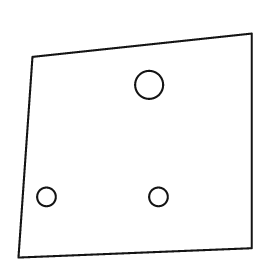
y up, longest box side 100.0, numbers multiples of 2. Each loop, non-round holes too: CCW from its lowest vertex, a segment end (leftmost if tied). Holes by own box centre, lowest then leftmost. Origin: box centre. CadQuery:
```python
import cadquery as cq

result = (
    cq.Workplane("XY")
    .moveTo(-50.0, -48.0)
    .lineTo(50.0, -44.0)
    .lineTo(50.0, 48.0)
    .lineTo(-44.0, 38.0)
    .close()
    .moveTo(-38.0, -22.0)
    .circle(4.0)
    .moveTo(10.0, -22.0)
    .circle(4.0)
    .moveTo(6.0, 26.0)
    .circle(6.0)
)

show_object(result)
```